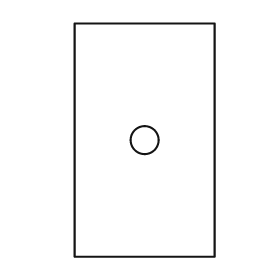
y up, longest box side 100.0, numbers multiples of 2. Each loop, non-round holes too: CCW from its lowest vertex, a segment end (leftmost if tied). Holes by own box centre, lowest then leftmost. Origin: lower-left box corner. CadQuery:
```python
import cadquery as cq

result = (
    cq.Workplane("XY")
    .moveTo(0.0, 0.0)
    .lineTo(60.0, 0.0)
    .lineTo(60.0, 100.0)
    .lineTo(0.0, 100.0)
    .close()
    .moveTo(30.0, 50.0)
    .circle(6.0)
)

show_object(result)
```